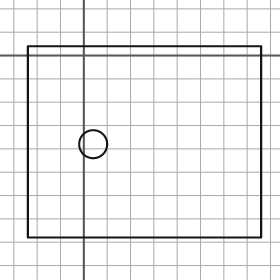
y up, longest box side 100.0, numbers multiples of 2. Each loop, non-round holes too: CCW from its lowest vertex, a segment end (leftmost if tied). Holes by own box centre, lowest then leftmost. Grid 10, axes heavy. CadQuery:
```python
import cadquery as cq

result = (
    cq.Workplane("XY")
    .moveTo(-24.0, -78.0)
    .lineTo(76.0, -78.0)
    .lineTo(76.0, 4.0)
    .lineTo(-24.0, 4.0)
    .close()
    .moveTo(4.0, -38.0)
    .circle(6.0)
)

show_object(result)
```